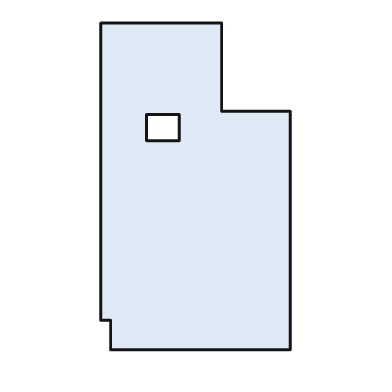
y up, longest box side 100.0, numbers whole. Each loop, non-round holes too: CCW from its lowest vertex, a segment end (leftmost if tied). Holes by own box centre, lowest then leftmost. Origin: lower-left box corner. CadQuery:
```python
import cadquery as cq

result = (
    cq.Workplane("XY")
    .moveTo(3.0, 0.0)
    .lineTo(58.0, 0.0)
    .lineTo(58.0, 73.0)
    .lineTo(37.0, 73.0)
    .lineTo(37.0, 100.0)
    .lineTo(0.0, 100.0)
    .lineTo(0.0, 9.0)
    .lineTo(3.0, 9.0)
    .close()
    .moveTo(14.0, 64.0)
    .lineTo(24.0, 64.0)
    .lineTo(24.0, 72.0)
    .lineTo(14.0, 72.0)
    .close()
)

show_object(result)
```